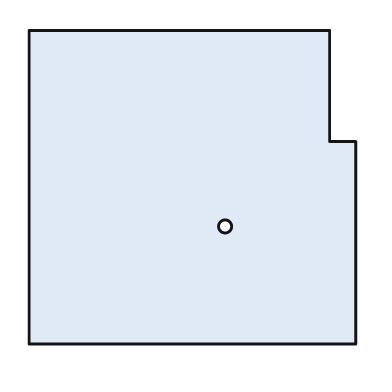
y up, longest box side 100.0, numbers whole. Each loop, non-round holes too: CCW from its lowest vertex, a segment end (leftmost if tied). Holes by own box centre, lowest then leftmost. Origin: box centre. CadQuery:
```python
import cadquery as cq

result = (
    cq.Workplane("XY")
    .moveTo(-50.0, -48.0)
    .lineTo(50.0, -48.0)
    .lineTo(50.0, 14.0)
    .lineTo(42.0, 14.0)
    .lineTo(42.0, 48.0)
    .lineTo(-50.0, 48.0)
    .close()
    .moveTo(10.0, -12.0)
    .circle(2.0)
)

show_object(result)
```